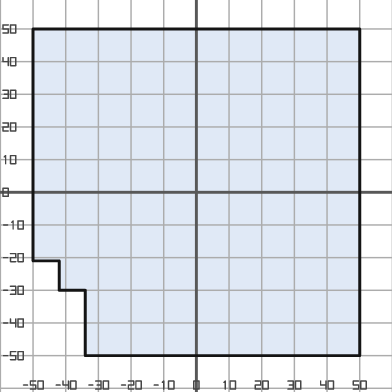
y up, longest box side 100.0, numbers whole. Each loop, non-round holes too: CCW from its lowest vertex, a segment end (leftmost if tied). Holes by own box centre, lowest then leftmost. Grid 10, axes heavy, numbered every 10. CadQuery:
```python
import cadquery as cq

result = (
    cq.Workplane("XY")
    .moveTo(-34.0, -50.0)
    .lineTo(50.0, -50.0)
    .lineTo(50.0, 50.0)
    .lineTo(-50.0, 50.0)
    .lineTo(-50.0, -21.0)
    .lineTo(-42.0, -21.0)
    .lineTo(-42.0, -30.0)
    .lineTo(-34.0, -30.0)
    .close()
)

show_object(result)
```